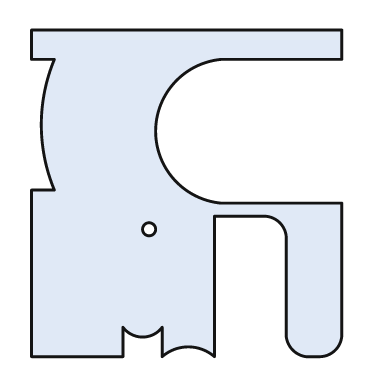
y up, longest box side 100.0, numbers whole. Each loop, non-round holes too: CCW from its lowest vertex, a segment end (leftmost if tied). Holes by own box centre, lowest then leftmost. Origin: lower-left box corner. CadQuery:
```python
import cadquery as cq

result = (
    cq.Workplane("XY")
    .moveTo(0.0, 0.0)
    .lineTo(28.0, 0.0)
    .lineTo(28.0, 9.0)
    .threePointArc((34.0, 6.0), (40.0, 9.0))
    .lineTo(40.0, 0.0)
    .threePointArc((48.0, 3.0), (56.0, 0.0))
    .lineTo(56.0, 43.0)
    .lineTo(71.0, 43.0)
    .threePointArc((76.0, 41.0), (78.0, 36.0))
    .lineTo(78.0, 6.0)
    .threePointArc((80.0, 2.0), (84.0, 0.0))
    .lineTo(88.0, 0.0)
    .threePointArc((93.0, 2.0), (95.0, 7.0))
    .lineTo(95.0, 47.0)
    .lineTo(58.0, 47.0)
    .threePointArc((38.0, 69.0), (58.0, 91.0))
    .lineTo(95.0, 91.0)
    .lineTo(95.0, 100.0)
    .lineTo(0.0, 100.0)
    .lineTo(0.0, 91.0)
    .lineTo(7.0, 91.0)
    .threePointArc((3.0, 71.0), (7.0, 51.0))
    .lineTo(0.0, 51.0)
    .close()
    .moveTo(36.0, 39.0)
    .circle(2.0)
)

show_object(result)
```